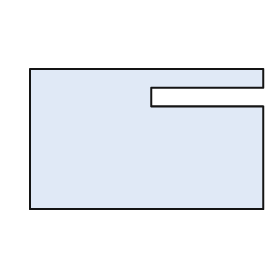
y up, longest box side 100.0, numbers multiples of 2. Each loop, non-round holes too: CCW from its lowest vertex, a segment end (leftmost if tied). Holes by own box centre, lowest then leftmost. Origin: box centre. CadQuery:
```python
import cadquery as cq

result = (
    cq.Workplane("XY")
    .moveTo(-50.0, -30.0)
    .lineTo(50.0, -30.0)
    .lineTo(50.0, 14.0)
    .lineTo(2.0, 14.0)
    .lineTo(2.0, 22.0)
    .lineTo(50.0, 22.0)
    .lineTo(50.0, 30.0)
    .lineTo(-50.0, 30.0)
    .close()
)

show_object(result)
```